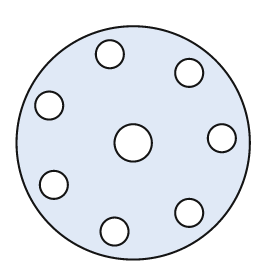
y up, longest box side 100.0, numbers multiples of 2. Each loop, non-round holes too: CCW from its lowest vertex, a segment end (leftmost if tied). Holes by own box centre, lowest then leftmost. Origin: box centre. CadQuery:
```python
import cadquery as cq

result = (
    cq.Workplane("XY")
    .moveTo(0.0, 0.0)
    .circle(50.0)
    .moveTo(-8.0, -38.0)
    .circle(6.0)
    .moveTo(24.0, -30.0)
    .circle(6.0)
    .moveTo(-34.0, -18.0)
    .circle(6.0)
    .moveTo(0.0, 0.0)
    .circle(8.0)
    .moveTo(38.0, 2.0)
    .circle(6.0)
    .moveTo(-36.0, 16.0)
    .circle(6.0)
    .moveTo(24.0, 30.0)
    .circle(6.0)
    .moveTo(-10.0, 38.0)
    .circle(6.0)
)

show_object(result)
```